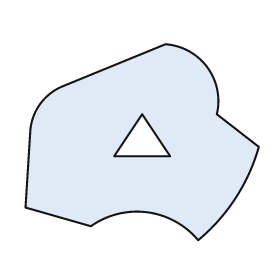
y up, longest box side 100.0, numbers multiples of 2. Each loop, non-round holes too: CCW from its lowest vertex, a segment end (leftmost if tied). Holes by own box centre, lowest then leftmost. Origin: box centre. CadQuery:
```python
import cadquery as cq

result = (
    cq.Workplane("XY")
    .moveTo(24.0, -42.0)
    .threePointArc((40.0, -24.0), (50.0, -2.0))
    .lineTo(32.0, 12.0)
    .threePointArc((28.0, 32.0), (10.0, 42.0))
    .lineTo(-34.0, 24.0)
    .threePointArc((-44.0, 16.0), (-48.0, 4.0))
    .lineTo(-50.0, -28.0)
    .lineTo(-22.0, -36.0)
    .threePointArc((2.0, -30.0), (24.0, -42.0))
    .close()
    .moveTo(-12.0, -6.0)
    .lineTo(12.0, -6.0)
    .lineTo(0.0, 12.0)
    .close()
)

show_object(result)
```